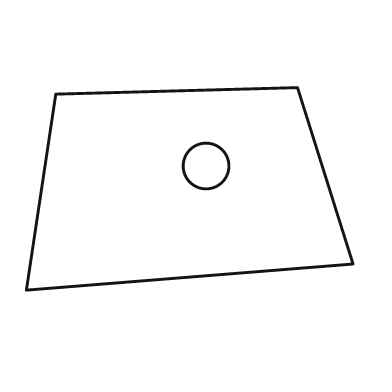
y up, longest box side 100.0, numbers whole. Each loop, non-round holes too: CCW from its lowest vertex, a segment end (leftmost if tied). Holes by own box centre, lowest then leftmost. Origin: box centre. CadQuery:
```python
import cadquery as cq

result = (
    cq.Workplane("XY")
    .moveTo(-50.0, -31.0)
    .lineTo(50.0, -23.0)
    .lineTo(33.0, 31.0)
    .lineTo(-41.0, 29.0)
    .close()
    .moveTo(5.0, 7.0)
    .circle(7.0)
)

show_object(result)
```